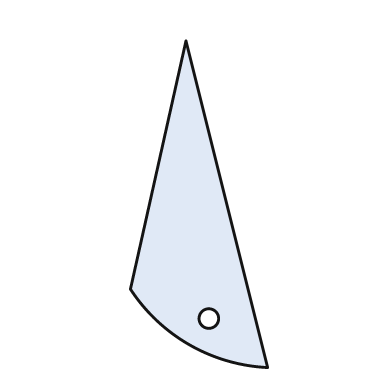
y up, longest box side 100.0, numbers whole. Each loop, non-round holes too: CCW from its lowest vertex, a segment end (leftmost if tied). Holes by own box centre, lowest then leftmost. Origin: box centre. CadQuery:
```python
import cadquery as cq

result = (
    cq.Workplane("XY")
    .moveTo(21.0, -50.0)
    .lineTo(-4.0, 50.0)
    .lineTo(-21.0, -26.0)
    .threePointArc((-3.0, -43.0), (21.0, -50.0))
    .close()
    .moveTo(3.0, -35.0)
    .circle(3.0)
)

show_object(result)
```